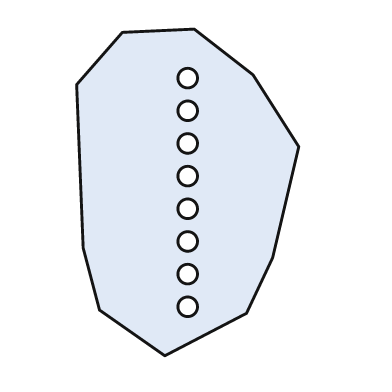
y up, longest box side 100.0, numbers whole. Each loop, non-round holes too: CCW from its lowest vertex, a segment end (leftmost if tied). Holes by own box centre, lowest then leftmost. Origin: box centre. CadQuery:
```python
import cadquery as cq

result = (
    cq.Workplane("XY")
    .moveTo(-7.0, -50.0)
    .lineTo(18.0, -37.0)
    .lineTo(26.0, -20.0)
    .lineTo(34.0, 14.0)
    .lineTo(20.0, 36.0)
    .lineTo(2.0, 50.0)
    .lineTo(-20.0, 49.0)
    .lineTo(-34.0, 33.0)
    .lineTo(-32.0, -17.0)
    .lineTo(-27.0, -36.0)
    .close()
    .moveTo(0.0, -35.0)
    .circle(3.0)
    .moveTo(0.0, -25.0)
    .circle(3.0)
    .moveTo(0.0, -15.0)
    .circle(3.0)
    .moveTo(0.0, -5.0)
    .circle(3.0)
    .moveTo(0.0, 5.0)
    .circle(3.0)
    .moveTo(0.0, 15.0)
    .circle(3.0)
    .moveTo(0.0, 25.0)
    .circle(3.0)
    .moveTo(0.0, 35.0)
    .circle(3.0)
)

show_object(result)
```